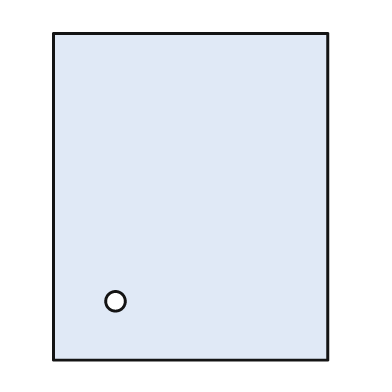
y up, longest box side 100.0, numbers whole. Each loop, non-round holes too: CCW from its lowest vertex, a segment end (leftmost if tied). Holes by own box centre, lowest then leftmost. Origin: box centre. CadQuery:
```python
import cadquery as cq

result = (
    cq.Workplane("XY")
    .moveTo(-42.0, -50.0)
    .lineTo(42.0, -50.0)
    .lineTo(42.0, 50.0)
    .lineTo(-42.0, 50.0)
    .close()
    .moveTo(-23.0, -32.0)
    .circle(3.0)
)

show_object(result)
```